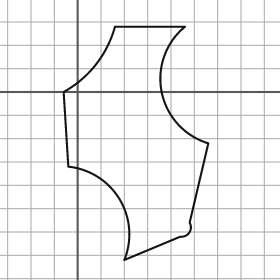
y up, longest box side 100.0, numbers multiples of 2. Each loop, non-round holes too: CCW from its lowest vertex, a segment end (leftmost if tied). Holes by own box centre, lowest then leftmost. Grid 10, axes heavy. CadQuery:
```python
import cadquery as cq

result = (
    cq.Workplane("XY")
    .moveTo(20.0, -72.0)
    .lineTo(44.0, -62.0)
    .threePointArc((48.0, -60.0), (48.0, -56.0))
    .lineTo(56.0, -22.0)
    .threePointArc((36.0, 0.0), (46.0, 28.0))
    .lineTo(16.0, 28.0)
    .threePointArc((8.0, 12.0), (-6.0, 0.0))
    .lineTo(-4.0, -32.0)
    .threePointArc((18.0, -46.0), (20.0, -72.0))
    .close()
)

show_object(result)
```